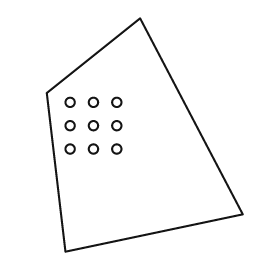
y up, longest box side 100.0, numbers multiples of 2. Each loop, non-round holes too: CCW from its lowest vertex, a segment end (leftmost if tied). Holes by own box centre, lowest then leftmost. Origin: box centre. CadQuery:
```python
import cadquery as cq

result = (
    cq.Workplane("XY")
    .moveTo(-34.0, -50.0)
    .lineTo(42.0, -34.0)
    .lineTo(-2.0, 50.0)
    .lineTo(-42.0, 18.0)
    .close()
    .moveTo(-32.0, -6.0)
    .circle(2.0)
    .moveTo(-22.0, -6.0)
    .circle(2.0)
    .moveTo(-12.0, -6.0)
    .circle(2.0)
    .moveTo(-32.0, 4.0)
    .circle(2.0)
    .moveTo(-22.0, 4.0)
    .circle(2.0)
    .moveTo(-12.0, 4.0)
    .circle(2.0)
    .moveTo(-32.0, 14.0)
    .circle(2.0)
    .moveTo(-22.0, 14.0)
    .circle(2.0)
    .moveTo(-12.0, 14.0)
    .circle(2.0)
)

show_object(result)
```